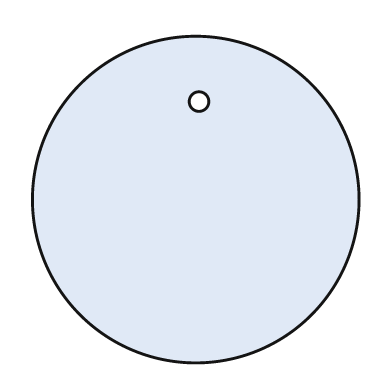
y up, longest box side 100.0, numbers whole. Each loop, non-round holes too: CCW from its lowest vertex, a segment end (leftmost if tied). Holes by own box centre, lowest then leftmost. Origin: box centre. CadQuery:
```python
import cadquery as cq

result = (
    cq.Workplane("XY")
    .moveTo(0.0, 0.0)
    .circle(50.0)
    .moveTo(1.0, 30.0)
    .circle(3.0)
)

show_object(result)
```